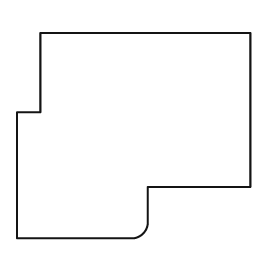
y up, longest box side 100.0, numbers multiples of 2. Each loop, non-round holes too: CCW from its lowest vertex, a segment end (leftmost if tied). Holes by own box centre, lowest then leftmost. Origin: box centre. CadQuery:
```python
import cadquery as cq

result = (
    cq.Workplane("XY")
    .moveTo(-50.0, -44.0)
    .lineTo(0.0, -44.0)
    .threePointArc((4.0, -42.0), (6.0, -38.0))
    .lineTo(6.0, -22.0)
    .lineTo(50.0, -22.0)
    .lineTo(50.0, 44.0)
    .lineTo(-40.0, 44.0)
    .lineTo(-40.0, 10.0)
    .lineTo(-50.0, 10.0)
    .close()
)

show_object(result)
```